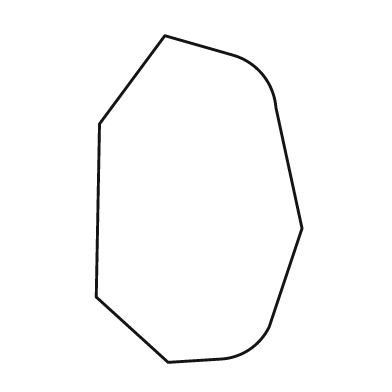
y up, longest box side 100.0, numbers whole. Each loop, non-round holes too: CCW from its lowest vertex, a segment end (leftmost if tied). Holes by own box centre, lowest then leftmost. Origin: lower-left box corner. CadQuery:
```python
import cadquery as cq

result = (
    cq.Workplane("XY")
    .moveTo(22.0, 0.0)
    .lineTo(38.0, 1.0)
    .threePointArc((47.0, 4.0), (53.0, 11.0))
    .lineTo(63.0, 41.0)
    .lineTo(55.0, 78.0)
    .threePointArc((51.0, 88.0), (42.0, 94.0))
    .lineTo(21.0, 100.0)
    .lineTo(1.0, 73.0)
    .lineTo(0.0, 20.0)
    .close()
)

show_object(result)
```